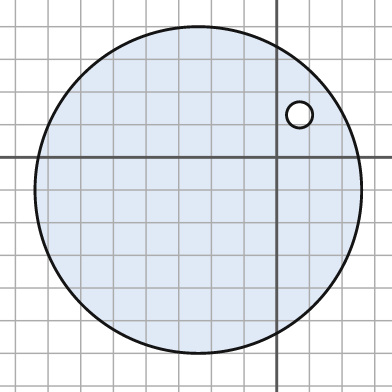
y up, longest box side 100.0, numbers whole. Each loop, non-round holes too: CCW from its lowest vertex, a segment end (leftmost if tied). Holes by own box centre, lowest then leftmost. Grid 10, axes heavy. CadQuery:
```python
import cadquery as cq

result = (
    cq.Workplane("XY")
    .moveTo(-24.0, -10.0)
    .circle(50.0)
    .moveTo(7.0, 13.0)
    .circle(4.0)
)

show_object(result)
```